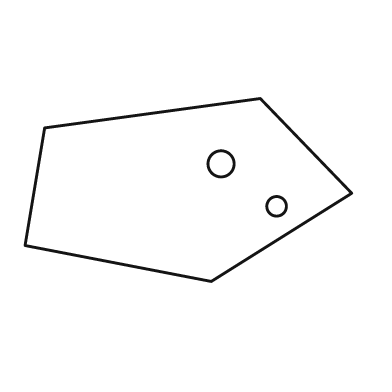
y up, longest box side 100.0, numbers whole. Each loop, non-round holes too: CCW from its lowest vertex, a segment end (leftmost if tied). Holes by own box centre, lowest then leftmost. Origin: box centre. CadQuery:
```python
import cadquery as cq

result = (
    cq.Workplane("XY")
    .moveTo(7.0, -28.0)
    .lineTo(50.0, -1.0)
    .lineTo(22.0, 28.0)
    .lineTo(-44.0, 19.0)
    .lineTo(-50.0, -17.0)
    .close()
    .moveTo(27.0, -5.0)
    .circle(3.0)
    .moveTo(10.0, 8.0)
    .circle(4.0)
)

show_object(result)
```